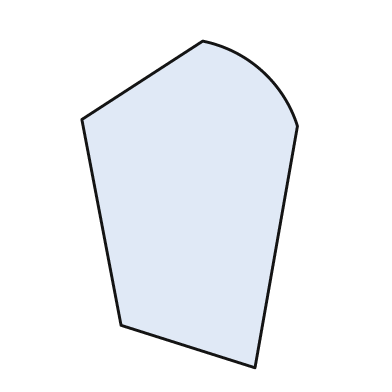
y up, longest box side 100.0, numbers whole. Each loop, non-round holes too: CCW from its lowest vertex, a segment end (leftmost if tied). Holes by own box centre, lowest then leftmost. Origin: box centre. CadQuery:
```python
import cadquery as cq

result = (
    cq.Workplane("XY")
    .moveTo(20.0, -50.0)
    .lineTo(33.0, 24.0)
    .threePointArc((22.0, 41.0), (4.0, 50.0))
    .lineTo(-33.0, 26.0)
    .lineTo(-21.0, -37.0)
    .close()
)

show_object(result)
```